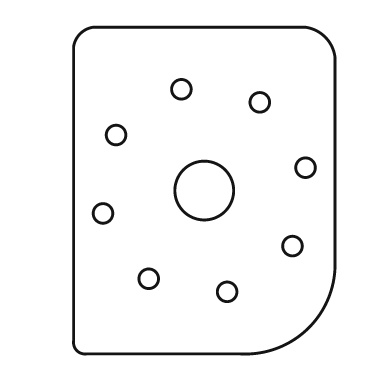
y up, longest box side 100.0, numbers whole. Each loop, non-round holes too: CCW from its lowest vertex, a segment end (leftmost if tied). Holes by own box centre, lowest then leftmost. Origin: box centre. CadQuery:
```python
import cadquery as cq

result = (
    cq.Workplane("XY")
    .moveTo(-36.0, -50.0)
    .lineTo(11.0, -50.0)
    .threePointArc((32.0, -42.0), (40.0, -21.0))
    .lineTo(40.0, 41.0)
    .threePointArc((37.0, 47.0), (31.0, 50.0))
    .lineTo(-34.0, 50.0)
    .threePointArc((-38.0, 48.0), (-40.0, 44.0))
    .lineTo(-40.0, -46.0)
    .threePointArc((-39.0, -49.0), (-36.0, -50.0))
    .close()
    .moveTo(7.0, -31.0)
    .circle(3.0)
    .moveTo(-17.0, -27.0)
    .circle(3.0)
    .moveTo(27.0, -17.0)
    .circle(3.0)
    .moveTo(-31.0, -7.0)
    .circle(3.0)
    .moveTo(0.0, 0.0)
    .circle(9.0)
    .moveTo(31.0, 7.0)
    .circle(3.0)
    .moveTo(-27.0, 17.0)
    .circle(3.0)
    .moveTo(17.0, 27.0)
    .circle(3.0)
    .moveTo(-7.0, 31.0)
    .circle(3.0)
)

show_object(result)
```